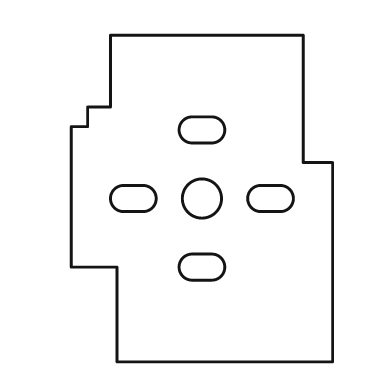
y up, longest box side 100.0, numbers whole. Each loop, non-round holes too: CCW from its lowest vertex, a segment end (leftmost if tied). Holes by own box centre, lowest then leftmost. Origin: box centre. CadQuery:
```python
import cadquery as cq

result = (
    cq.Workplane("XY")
    .moveTo(-26.0, -50.0)
    .lineTo(40.0, -50.0)
    .lineTo(40.0, 11.0)
    .lineTo(31.0, 11.0)
    .lineTo(31.0, 50.0)
    .lineTo(-28.0, 50.0)
    .lineTo(-28.0, 28.0)
    .lineTo(-35.0, 28.0)
    .lineTo(-35.0, 22.0)
    .lineTo(-40.0, 22.0)
    .lineTo(-40.0, -21.0)
    .lineTo(-26.0, -21.0)
    .close()
    .moveTo(-3.0, -25.0)
    .lineTo(3.0, -25.0)
    .threePointArc((7.0, -21.0), (3.0, -17.0))
    .lineTo(-3.0, -17.0)
    .threePointArc((-7.0, -21.0), (-3.0, -25.0))
    .close()
    .moveTo(-24.0, -4.0)
    .lineTo(-18.0, -4.0)
    .threePointArc((-14.0, 0.0), (-18.0, 4.0))
    .lineTo(-24.0, 4.0)
    .threePointArc((-28.0, 0.0), (-24.0, -4.0))
    .close()
    .moveTo(0.0, 0.0)
    .circle(6.0)
    .moveTo(18.0, -4.0)
    .lineTo(24.0, -4.0)
    .threePointArc((28.0, 0.0), (24.0, 4.0))
    .lineTo(18.0, 4.0)
    .threePointArc((14.0, 0.0), (18.0, -4.0))
    .close()
    .moveTo(-3.0, 17.0)
    .lineTo(3.0, 17.0)
    .threePointArc((7.0, 21.0), (3.0, 25.0))
    .lineTo(-3.0, 25.0)
    .threePointArc((-7.0, 21.0), (-3.0, 17.0))
    .close()
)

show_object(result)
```